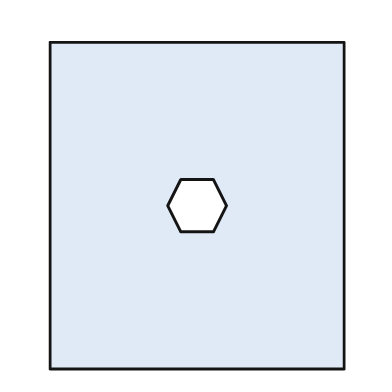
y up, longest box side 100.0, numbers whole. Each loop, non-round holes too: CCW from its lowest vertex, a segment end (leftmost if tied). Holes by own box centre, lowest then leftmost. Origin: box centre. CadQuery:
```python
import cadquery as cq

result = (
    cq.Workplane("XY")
    .moveTo(-45.0, -50.0)
    .lineTo(45.0, -50.0)
    .lineTo(45.0, 50.0)
    .lineTo(-45.0, 50.0)
    .close()
    .moveTo(-5.0, -8.0)
    .lineTo(5.0, -8.0)
    .lineTo(9.0, 0.0)
    .lineTo(5.0, 8.0)
    .lineTo(-5.0, 8.0)
    .lineTo(-9.0, 0.0)
    .close()
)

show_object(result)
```